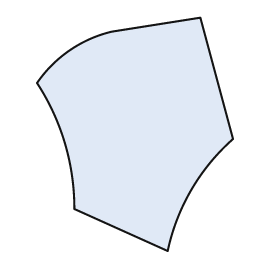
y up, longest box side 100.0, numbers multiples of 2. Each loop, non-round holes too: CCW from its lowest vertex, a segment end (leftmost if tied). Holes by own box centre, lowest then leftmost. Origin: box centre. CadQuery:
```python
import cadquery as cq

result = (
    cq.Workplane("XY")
    .moveTo(14.0, -50.0)
    .threePointArc((24.0, -24.0), (42.0, -2.0))
    .lineTo(28.0, 50.0)
    .lineTo(-10.0, 44.0)
    .threePointArc((-28.0, 36.0), (-42.0, 22.0))
    .threePointArc((-30.0, -4.0), (-26.0, -32.0))
    .close()
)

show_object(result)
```